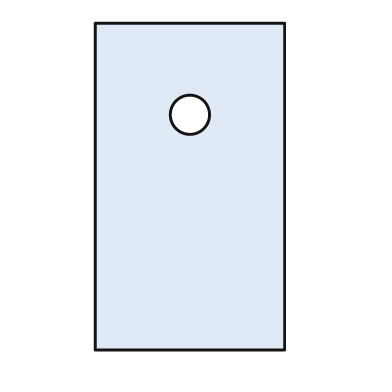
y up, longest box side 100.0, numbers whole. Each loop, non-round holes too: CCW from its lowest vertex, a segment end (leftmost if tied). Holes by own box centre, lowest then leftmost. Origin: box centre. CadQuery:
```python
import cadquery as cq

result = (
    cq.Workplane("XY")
    .moveTo(-29.0, -50.0)
    .lineTo(29.0, -50.0)
    .lineTo(29.0, 50.0)
    .lineTo(-29.0, 50.0)
    .close()
    .moveTo(0.0, 22.0)
    .circle(6.0)
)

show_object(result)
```